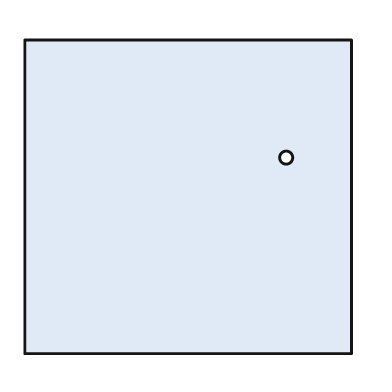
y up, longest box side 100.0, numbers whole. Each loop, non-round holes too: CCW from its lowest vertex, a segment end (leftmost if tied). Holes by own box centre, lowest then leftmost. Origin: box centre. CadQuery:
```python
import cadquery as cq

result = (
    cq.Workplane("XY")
    .moveTo(-50.0, -48.0)
    .lineTo(50.0, -48.0)
    .lineTo(50.0, 48.0)
    .lineTo(-50.0, 48.0)
    .close()
    .moveTo(30.0, 12.0)
    .circle(2.0)
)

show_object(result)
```